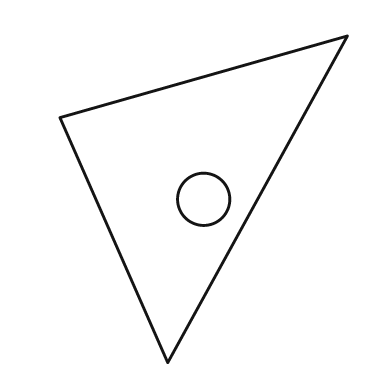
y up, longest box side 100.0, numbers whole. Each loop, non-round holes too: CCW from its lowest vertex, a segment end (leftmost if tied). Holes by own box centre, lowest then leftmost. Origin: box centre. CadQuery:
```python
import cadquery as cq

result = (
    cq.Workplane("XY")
    .moveTo(-11.0, -50.0)
    .lineTo(44.0, 50.0)
    .lineTo(-44.0, 25.0)
    .close()
    .moveTo(0.0, 0.0)
    .circle(8.0)
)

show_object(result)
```